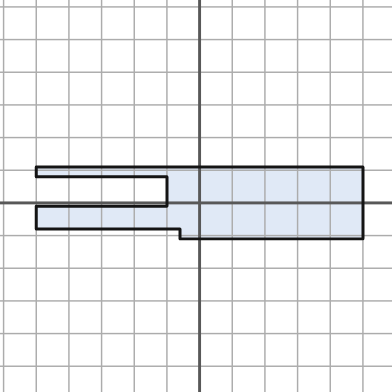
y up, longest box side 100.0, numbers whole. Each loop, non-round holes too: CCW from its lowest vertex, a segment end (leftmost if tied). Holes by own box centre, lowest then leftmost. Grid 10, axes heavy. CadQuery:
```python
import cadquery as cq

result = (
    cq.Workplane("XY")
    .moveTo(-6.0, -11.0)
    .lineTo(50.0, -11.0)
    .lineTo(50.0, 11.0)
    .lineTo(-50.0, 11.0)
    .lineTo(-50.0, 8.0)
    .lineTo(-10.0, 8.0)
    .lineTo(-10.0, -1.0)
    .lineTo(-50.0, -1.0)
    .lineTo(-50.0, -8.0)
    .lineTo(-6.0, -8.0)
    .close()
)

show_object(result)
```